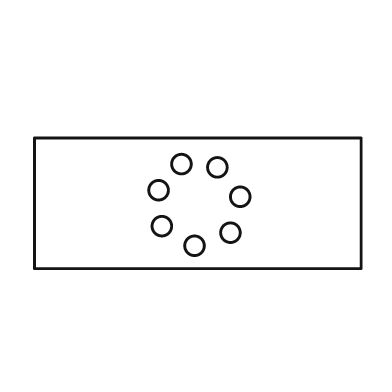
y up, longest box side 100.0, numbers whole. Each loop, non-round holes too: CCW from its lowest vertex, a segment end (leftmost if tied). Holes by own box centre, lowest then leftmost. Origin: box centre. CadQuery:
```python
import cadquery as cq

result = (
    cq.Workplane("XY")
    .moveTo(-50.0, -20.0)
    .lineTo(50.0, -20.0)
    .lineTo(50.0, 20.0)
    .lineTo(-50.0, 20.0)
    .close()
    .moveTo(-1.0, -13.0)
    .circle(3.0)
    .moveTo(10.0, -9.0)
    .circle(3.0)
    .moveTo(-11.0, -7.0)
    .circle(3.0)
    .moveTo(13.0, 2.0)
    .circle(3.0)
    .moveTo(-12.0, 4.0)
    .circle(3.0)
    .moveTo(6.0, 11.0)
    .circle(3.0)
    .moveTo(-5.0, 12.0)
    .circle(3.0)
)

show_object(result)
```